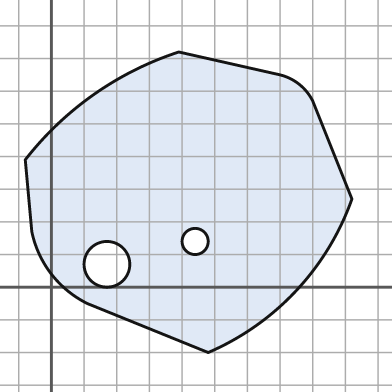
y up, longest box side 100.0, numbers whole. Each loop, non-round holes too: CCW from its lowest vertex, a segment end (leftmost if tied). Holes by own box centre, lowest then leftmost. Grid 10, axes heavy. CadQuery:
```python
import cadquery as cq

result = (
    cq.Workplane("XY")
    .moveTo(48.0, -20.0)
    .threePointArc((75.0, -1.0), (92.0, 27.0))
    .lineTo(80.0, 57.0)
    .threePointArc((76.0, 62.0), (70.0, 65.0))
    .lineTo(39.0, 72.0)
    .threePointArc((13.0, 59.0), (-8.0, 39.0))
    .lineTo(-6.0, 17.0)
    .threePointArc((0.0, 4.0), (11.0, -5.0))
    .close()
    .moveTo(17.0, 7.0)
    .circle(7.0)
    .moveTo(44.0, 14.0)
    .circle(4.0)
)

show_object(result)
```